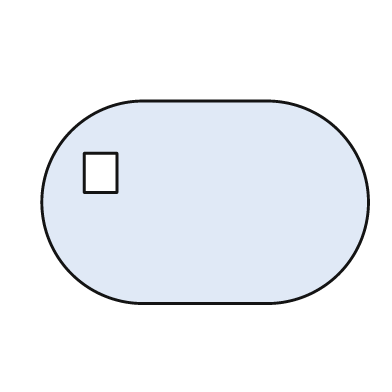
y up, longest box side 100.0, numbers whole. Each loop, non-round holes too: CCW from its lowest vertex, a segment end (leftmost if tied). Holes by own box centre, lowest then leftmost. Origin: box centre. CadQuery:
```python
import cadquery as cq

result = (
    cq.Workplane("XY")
    .moveTo(-19.0, -31.0)
    .lineTo(19.0, -31.0)
    .threePointArc((50.0, 0.0), (19.0, 31.0))
    .lineTo(-19.0, 31.0)
    .threePointArc((-50.0, 0.0), (-19.0, -31.0))
    .close()
    .moveTo(-37.0, 3.0)
    .lineTo(-27.0, 3.0)
    .lineTo(-27.0, 15.0)
    .lineTo(-37.0, 15.0)
    .close()
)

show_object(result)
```